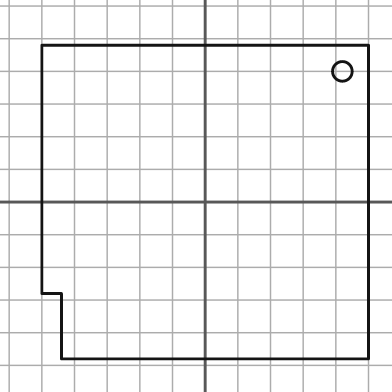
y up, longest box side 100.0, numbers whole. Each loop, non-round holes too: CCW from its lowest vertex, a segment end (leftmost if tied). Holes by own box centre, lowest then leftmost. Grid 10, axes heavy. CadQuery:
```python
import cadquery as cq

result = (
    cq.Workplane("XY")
    .moveTo(-44.0, -48.0)
    .lineTo(50.0, -48.0)
    .lineTo(50.0, 48.0)
    .lineTo(-50.0, 48.0)
    .lineTo(-50.0, -28.0)
    .lineTo(-44.0, -28.0)
    .close()
    .moveTo(42.0, 40.0)
    .circle(3.0)
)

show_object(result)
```